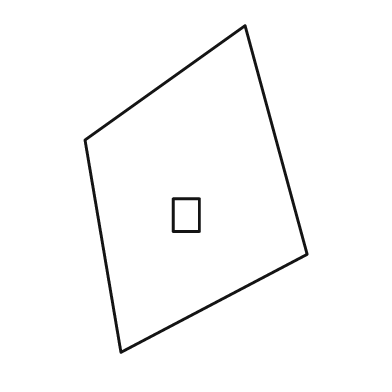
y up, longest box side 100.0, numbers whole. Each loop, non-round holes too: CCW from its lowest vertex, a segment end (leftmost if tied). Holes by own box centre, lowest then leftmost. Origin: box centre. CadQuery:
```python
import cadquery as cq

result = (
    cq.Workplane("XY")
    .moveTo(-23.0, -50.0)
    .lineTo(34.0, -20.0)
    .lineTo(15.0, 50.0)
    .lineTo(-34.0, 15.0)
    .close()
    .moveTo(-7.0, -13.0)
    .lineTo(1.0, -13.0)
    .lineTo(1.0, -3.0)
    .lineTo(-7.0, -3.0)
    .close()
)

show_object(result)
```